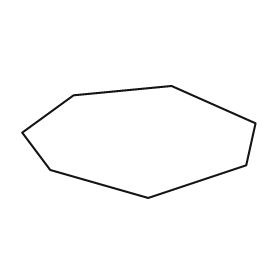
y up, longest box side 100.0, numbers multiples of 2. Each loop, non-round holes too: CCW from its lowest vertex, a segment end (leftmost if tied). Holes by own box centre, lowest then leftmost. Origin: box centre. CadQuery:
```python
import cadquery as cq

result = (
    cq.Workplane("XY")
    .moveTo(4.0, -24.0)
    .lineTo(46.0, -10.0)
    .lineTo(50.0, 8.0)
    .lineTo(14.0, 24.0)
    .lineTo(-28.0, 20.0)
    .lineTo(-50.0, 4.0)
    .lineTo(-38.0, -12.0)
    .close()
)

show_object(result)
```